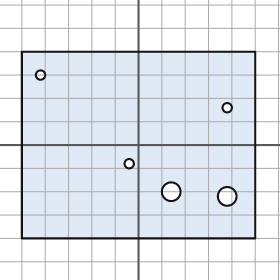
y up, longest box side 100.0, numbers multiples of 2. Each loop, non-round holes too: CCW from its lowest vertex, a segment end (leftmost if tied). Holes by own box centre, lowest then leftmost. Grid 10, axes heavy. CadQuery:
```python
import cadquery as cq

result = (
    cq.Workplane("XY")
    .moveTo(-50.0, -40.0)
    .lineTo(50.0, -40.0)
    .lineTo(50.0, 40.0)
    .lineTo(-50.0, 40.0)
    .close()
    .moveTo(38.0, -22.0)
    .circle(4.0)
    .moveTo(14.0, -20.0)
    .circle(4.0)
    .moveTo(-4.0, -8.0)
    .circle(2.0)
    .moveTo(38.0, 16.0)
    .circle(2.0)
    .moveTo(-42.0, 30.0)
    .circle(2.0)
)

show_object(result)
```